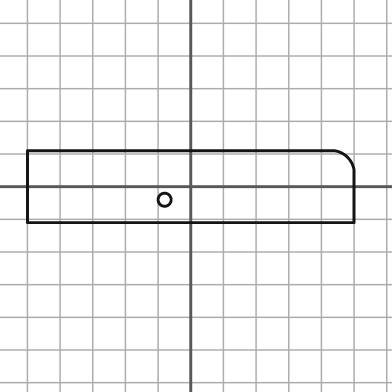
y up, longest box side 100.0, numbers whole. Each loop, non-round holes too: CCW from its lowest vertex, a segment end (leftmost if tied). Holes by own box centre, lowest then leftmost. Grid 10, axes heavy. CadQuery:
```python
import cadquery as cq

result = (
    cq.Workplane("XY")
    .moveTo(-50.0, -11.0)
    .lineTo(50.0, -11.0)
    .lineTo(50.0, 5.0)
    .threePointArc((48.0, 9.0), (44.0, 11.0))
    .lineTo(-50.0, 11.0)
    .close()
    .moveTo(-8.0, -4.0)
    .circle(2.0)
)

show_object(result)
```